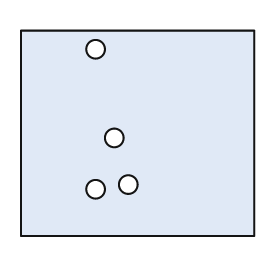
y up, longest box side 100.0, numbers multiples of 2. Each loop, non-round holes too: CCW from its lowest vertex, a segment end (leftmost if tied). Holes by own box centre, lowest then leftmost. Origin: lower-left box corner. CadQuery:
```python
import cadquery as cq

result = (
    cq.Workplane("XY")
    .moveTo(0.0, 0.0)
    .lineTo(100.0, 0.0)
    .lineTo(100.0, 88.0)
    .lineTo(0.0, 88.0)
    .close()
    .moveTo(32.0, 20.0)
    .circle(4.0)
    .moveTo(46.0, 22.0)
    .circle(4.0)
    .moveTo(40.0, 42.0)
    .circle(4.0)
    .moveTo(32.0, 80.0)
    .circle(4.0)
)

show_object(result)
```